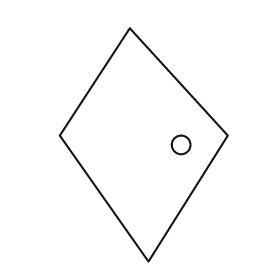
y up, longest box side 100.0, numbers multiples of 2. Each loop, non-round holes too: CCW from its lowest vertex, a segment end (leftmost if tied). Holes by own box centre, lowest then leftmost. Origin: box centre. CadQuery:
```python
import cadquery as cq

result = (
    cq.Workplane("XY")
    .moveTo(2.0, -50.0)
    .lineTo(36.0, 4.0)
    .lineTo(-6.0, 50.0)
    .lineTo(-36.0, 4.0)
    .close()
    .moveTo(16.0, 0.0)
    .circle(4.0)
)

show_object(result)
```